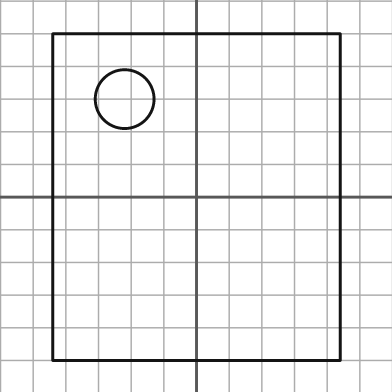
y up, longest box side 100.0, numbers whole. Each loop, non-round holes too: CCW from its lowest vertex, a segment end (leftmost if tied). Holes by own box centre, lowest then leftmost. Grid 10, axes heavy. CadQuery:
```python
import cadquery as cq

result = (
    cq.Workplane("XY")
    .moveTo(-44.0, -50.0)
    .lineTo(44.0, -50.0)
    .lineTo(44.0, 50.0)
    .lineTo(-44.0, 50.0)
    .close()
    .moveTo(-22.0, 30.0)
    .circle(9.0)
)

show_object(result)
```